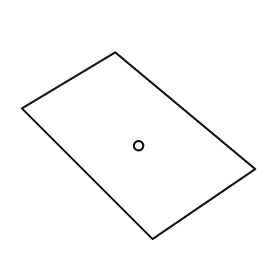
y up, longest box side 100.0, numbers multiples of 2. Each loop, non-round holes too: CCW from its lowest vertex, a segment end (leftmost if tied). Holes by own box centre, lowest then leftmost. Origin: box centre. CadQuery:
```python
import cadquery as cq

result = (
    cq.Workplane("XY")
    .moveTo(6.0, -40.0)
    .lineTo(50.0, -10.0)
    .lineTo(-10.0, 40.0)
    .lineTo(-50.0, 16.0)
    .close()
    .moveTo(0.0, 0.0)
    .circle(2.0)
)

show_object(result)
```